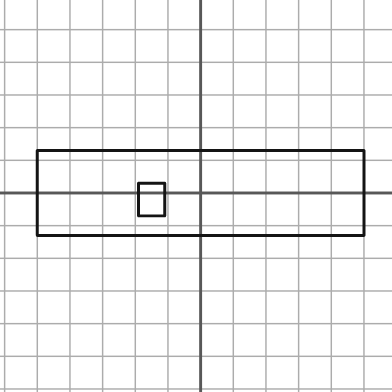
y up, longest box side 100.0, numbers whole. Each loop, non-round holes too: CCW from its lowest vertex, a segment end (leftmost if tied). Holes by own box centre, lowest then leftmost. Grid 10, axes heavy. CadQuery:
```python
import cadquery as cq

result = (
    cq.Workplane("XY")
    .moveTo(-50.0, -13.0)
    .lineTo(50.0, -13.0)
    .lineTo(50.0, 13.0)
    .lineTo(-50.0, 13.0)
    .close()
    .moveTo(-19.0, -7.0)
    .lineTo(-11.0, -7.0)
    .lineTo(-11.0, 3.0)
    .lineTo(-19.0, 3.0)
    .close()
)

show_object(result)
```